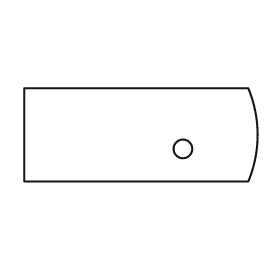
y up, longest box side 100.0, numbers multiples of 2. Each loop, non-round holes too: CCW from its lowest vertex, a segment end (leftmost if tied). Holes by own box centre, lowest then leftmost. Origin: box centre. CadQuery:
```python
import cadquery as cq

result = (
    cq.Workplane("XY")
    .moveTo(-50.0, -20.0)
    .lineTo(46.0, -20.0)
    .threePointArc((50.0, 0.0), (46.0, 20.0))
    .lineTo(-50.0, 20.0)
    .close()
    .moveTo(18.0, -6.0)
    .circle(4.0)
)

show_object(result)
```